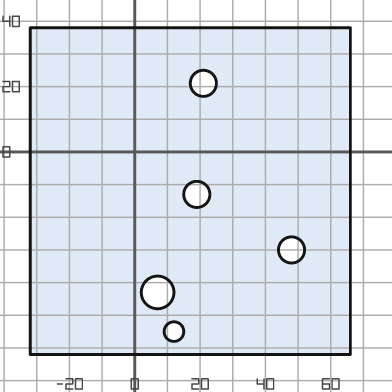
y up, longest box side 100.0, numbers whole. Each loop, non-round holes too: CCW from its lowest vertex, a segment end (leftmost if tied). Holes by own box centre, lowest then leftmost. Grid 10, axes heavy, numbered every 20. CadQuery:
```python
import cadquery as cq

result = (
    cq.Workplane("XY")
    .moveTo(-32.0, -62.0)
    .lineTo(66.0, -62.0)
    .lineTo(66.0, 38.0)
    .lineTo(-32.0, 38.0)
    .close()
    .moveTo(12.0, -55.0)
    .circle(3.0)
    .moveTo(7.0, -43.0)
    .circle(5.0)
    .moveTo(48.0, -30.0)
    .circle(4.0)
    .moveTo(19.0, -13.0)
    .circle(4.0)
    .moveTo(21.0, 21.0)
    .circle(4.0)
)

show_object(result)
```